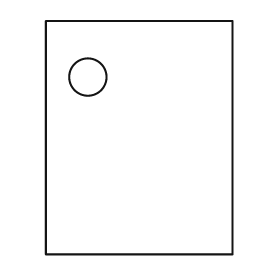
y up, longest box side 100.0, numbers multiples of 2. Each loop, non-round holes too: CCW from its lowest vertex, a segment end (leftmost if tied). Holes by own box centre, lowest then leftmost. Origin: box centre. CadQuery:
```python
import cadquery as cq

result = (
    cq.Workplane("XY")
    .moveTo(-40.0, -50.0)
    .lineTo(40.0, -50.0)
    .lineTo(40.0, 50.0)
    .lineTo(-40.0, 50.0)
    .close()
    .moveTo(-22.0, 26.0)
    .circle(8.0)
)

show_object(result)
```